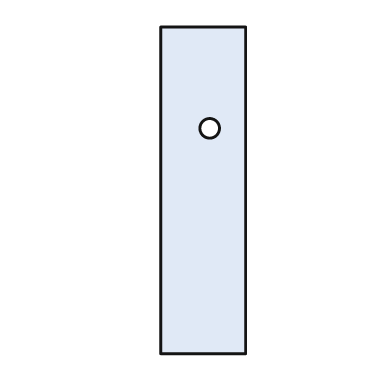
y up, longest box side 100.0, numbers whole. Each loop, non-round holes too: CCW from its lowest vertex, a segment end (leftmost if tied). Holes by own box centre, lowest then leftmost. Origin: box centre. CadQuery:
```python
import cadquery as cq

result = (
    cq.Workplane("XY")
    .moveTo(-13.0, -50.0)
    .lineTo(13.0, -50.0)
    .lineTo(13.0, 50.0)
    .lineTo(-13.0, 50.0)
    .close()
    .moveTo(2.0, 19.0)
    .circle(3.0)
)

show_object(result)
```